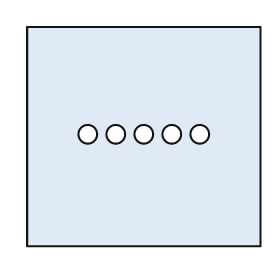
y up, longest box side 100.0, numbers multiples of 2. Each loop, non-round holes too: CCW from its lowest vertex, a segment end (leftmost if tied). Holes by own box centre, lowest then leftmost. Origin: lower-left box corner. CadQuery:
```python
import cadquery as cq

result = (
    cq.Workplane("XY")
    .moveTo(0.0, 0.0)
    .lineTo(100.0, 0.0)
    .lineTo(100.0, 94.0)
    .lineTo(0.0, 94.0)
    .close()
    .moveTo(26.0, 48.0)
    .circle(4.0)
    .moveTo(38.0, 48.0)
    .circle(4.0)
    .moveTo(50.0, 48.0)
    .circle(4.0)
    .moveTo(62.0, 48.0)
    .circle(4.0)
    .moveTo(74.0, 48.0)
    .circle(4.0)
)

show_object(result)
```